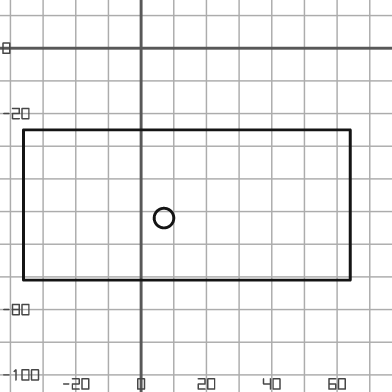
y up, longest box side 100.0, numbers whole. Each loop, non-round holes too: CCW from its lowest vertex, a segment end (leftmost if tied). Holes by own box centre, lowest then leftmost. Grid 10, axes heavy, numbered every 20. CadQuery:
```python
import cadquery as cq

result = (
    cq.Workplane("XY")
    .moveTo(-36.0, -71.0)
    .lineTo(64.0, -71.0)
    .lineTo(64.0, -25.0)
    .lineTo(-36.0, -25.0)
    .close()
    .moveTo(7.0, -52.0)
    .circle(3.0)
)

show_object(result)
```